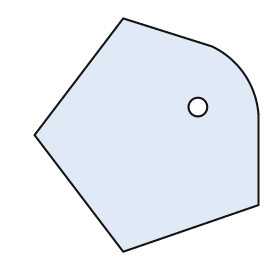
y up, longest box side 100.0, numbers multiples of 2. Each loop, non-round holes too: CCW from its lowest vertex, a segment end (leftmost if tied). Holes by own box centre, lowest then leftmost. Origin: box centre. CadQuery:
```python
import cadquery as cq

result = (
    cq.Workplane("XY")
    .moveTo(-10.0, -50.0)
    .lineTo(48.0, -30.0)
    .lineTo(48.0, 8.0)
    .threePointArc((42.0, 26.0), (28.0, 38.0))
    .lineTo(-10.0, 50.0)
    .lineTo(-48.0, 0.0)
    .close()
    .moveTo(22.0, 12.0)
    .circle(4.0)
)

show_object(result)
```